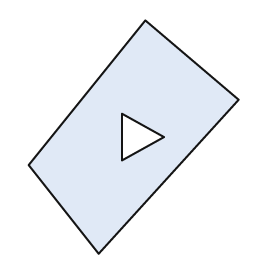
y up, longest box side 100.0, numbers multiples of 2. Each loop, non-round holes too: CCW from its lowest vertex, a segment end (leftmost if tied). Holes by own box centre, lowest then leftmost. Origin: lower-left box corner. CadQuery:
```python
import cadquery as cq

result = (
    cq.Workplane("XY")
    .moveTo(30.0, 0.0)
    .lineTo(90.0, 66.0)
    .lineTo(50.0, 100.0)
    .lineTo(0.0, 38.0)
    .close()
    .moveTo(40.0, 40.0)
    .lineTo(58.0, 50.0)
    .lineTo(40.0, 60.0)
    .close()
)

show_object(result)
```